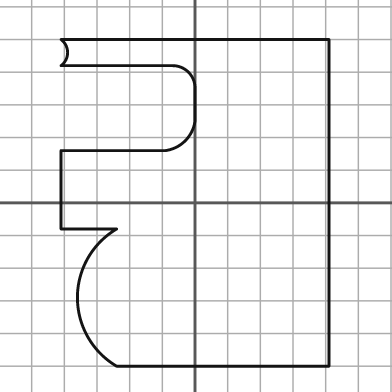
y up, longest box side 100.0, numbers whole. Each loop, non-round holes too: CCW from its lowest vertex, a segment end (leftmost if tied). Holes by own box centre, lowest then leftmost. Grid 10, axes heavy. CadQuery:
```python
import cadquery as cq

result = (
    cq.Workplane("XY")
    .moveTo(-24.0, -50.0)
    .lineTo(41.0, -50.0)
    .lineTo(41.0, 50.0)
    .lineTo(-41.0, 50.0)
    .threePointArc((-39.0, 46.0), (-41.0, 42.0))
    .lineTo(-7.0, 42.0)
    .threePointArc((-2.0, 40.0), (0.0, 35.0))
    .lineTo(0.0, 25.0)
    .threePointArc((-3.0, 19.0), (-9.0, 16.0))
    .lineTo(-41.0, 16.0)
    .lineTo(-41.0, -8.0)
    .lineTo(-24.0, -8.0)
    .threePointArc((-36.0, -29.0), (-24.0, -50.0))
    .close()
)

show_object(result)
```